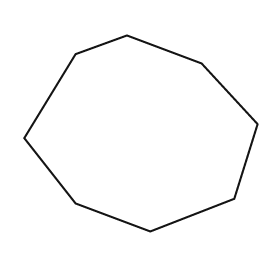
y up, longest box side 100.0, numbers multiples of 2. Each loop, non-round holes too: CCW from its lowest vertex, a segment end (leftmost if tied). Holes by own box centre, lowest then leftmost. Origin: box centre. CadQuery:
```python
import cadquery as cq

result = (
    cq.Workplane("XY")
    .moveTo(4.0, -42.0)
    .lineTo(40.0, -28.0)
    .lineTo(50.0, 4.0)
    .lineTo(26.0, 30.0)
    .lineTo(-6.0, 42.0)
    .lineTo(-28.0, 34.0)
    .lineTo(-50.0, -2.0)
    .lineTo(-28.0, -30.0)
    .close()
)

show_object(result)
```